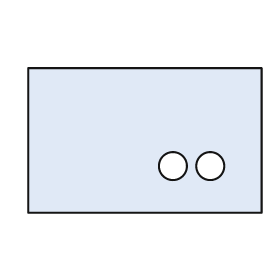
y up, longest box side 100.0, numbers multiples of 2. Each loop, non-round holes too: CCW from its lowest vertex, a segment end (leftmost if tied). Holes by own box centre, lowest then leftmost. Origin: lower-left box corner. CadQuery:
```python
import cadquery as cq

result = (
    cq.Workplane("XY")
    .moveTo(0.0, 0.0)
    .lineTo(100.0, 0.0)
    .lineTo(100.0, 62.0)
    .lineTo(0.0, 62.0)
    .close()
    .moveTo(62.0, 20.0)
    .circle(6.0)
    .moveTo(78.0, 20.0)
    .circle(6.0)
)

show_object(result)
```